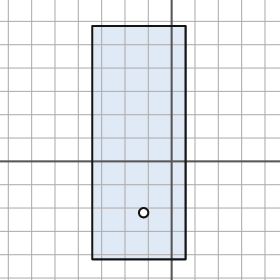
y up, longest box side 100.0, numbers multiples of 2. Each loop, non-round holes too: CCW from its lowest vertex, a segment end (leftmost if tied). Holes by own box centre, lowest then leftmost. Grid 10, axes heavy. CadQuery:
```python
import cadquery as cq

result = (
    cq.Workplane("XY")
    .moveTo(-34.0, -42.0)
    .lineTo(6.0, -42.0)
    .lineTo(6.0, 58.0)
    .lineTo(-34.0, 58.0)
    .close()
    .moveTo(-12.0, -22.0)
    .circle(2.0)
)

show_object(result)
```